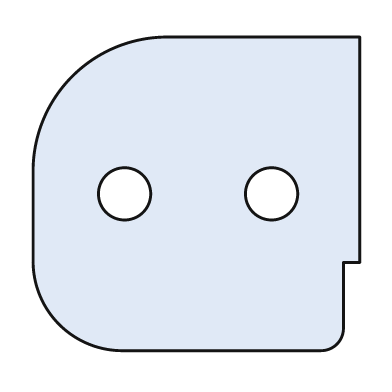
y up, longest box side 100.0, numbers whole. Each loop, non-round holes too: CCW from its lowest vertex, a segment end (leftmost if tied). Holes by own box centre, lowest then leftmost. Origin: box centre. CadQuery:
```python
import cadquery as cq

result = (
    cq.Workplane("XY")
    .moveTo(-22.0, -48.0)
    .lineTo(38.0, -48.0)
    .threePointArc((43.0, -46.0), (45.0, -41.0))
    .lineTo(45.0, -21.0)
    .lineTo(50.0, -21.0)
    .lineTo(50.0, 48.0)
    .lineTo(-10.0, 48.0)
    .threePointArc((-38.0, 36.0), (-50.0, 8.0))
    .lineTo(-50.0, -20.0)
    .threePointArc((-42.0, -40.0), (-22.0, -48.0))
    .close()
    .moveTo(-22.0, 0.0)
    .circle(8.0)
    .moveTo(23.0, 0.0)
    .circle(8.0)
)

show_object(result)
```